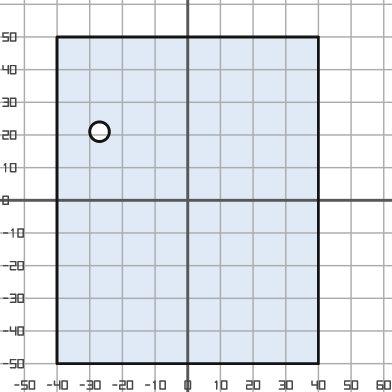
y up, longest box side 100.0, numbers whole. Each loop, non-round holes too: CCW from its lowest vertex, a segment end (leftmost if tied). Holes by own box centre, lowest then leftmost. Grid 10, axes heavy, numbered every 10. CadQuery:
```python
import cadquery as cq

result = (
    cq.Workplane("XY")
    .moveTo(-40.0, -50.0)
    .lineTo(40.0, -50.0)
    .lineTo(40.0, 50.0)
    .lineTo(-40.0, 50.0)
    .close()
    .moveTo(-27.0, 21.0)
    .circle(3.0)
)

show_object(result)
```